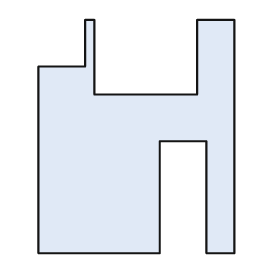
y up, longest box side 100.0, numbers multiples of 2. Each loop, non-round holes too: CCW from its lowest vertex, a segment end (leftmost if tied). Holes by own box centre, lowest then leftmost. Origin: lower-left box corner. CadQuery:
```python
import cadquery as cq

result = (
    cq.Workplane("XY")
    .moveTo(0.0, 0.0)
    .lineTo(52.0, 0.0)
    .lineTo(52.0, 48.0)
    .lineTo(72.0, 48.0)
    .lineTo(72.0, 0.0)
    .lineTo(84.0, 0.0)
    .lineTo(84.0, 100.0)
    .lineTo(68.0, 100.0)
    .lineTo(68.0, 68.0)
    .lineTo(24.0, 68.0)
    .lineTo(24.0, 100.0)
    .lineTo(20.0, 100.0)
    .lineTo(20.0, 80.0)
    .lineTo(0.0, 80.0)
    .close()
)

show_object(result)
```